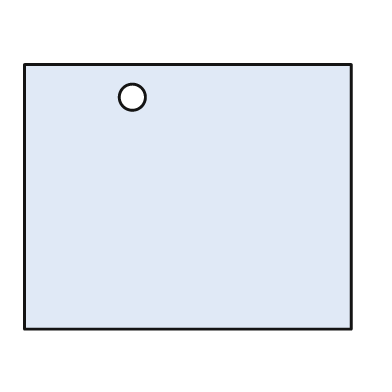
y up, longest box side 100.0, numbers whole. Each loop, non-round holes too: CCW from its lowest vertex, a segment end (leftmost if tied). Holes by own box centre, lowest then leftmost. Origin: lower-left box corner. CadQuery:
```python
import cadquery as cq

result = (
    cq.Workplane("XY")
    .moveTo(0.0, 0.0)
    .lineTo(100.0, 0.0)
    .lineTo(100.0, 81.0)
    .lineTo(0.0, 81.0)
    .close()
    .moveTo(33.0, 71.0)
    .circle(4.0)
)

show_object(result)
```